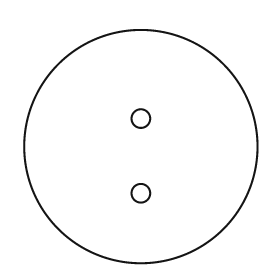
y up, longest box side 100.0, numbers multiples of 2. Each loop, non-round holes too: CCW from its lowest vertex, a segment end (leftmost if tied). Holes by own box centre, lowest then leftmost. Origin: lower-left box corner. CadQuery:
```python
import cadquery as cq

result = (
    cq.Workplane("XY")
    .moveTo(50.0, 50.0)
    .circle(50.0)
    .moveTo(50.0, 30.0)
    .circle(4.0)
    .moveTo(50.0, 62.0)
    .circle(4.0)
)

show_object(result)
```